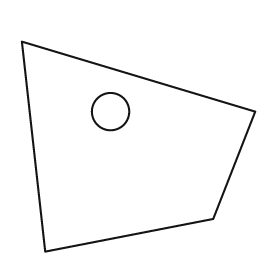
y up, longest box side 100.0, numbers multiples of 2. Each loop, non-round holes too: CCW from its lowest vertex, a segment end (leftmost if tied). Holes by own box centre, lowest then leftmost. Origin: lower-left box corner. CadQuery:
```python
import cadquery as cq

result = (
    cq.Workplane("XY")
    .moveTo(10.0, 0.0)
    .lineTo(82.0, 14.0)
    .lineTo(100.0, 60.0)
    .lineTo(0.0, 90.0)
    .close()
    .moveTo(38.0, 60.0)
    .circle(8.0)
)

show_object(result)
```